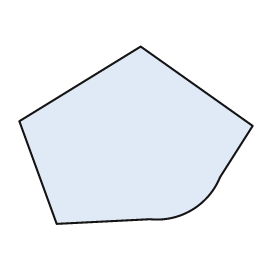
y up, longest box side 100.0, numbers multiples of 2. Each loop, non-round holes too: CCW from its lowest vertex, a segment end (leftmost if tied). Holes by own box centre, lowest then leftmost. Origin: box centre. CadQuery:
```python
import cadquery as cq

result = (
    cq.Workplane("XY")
    .moveTo(-34.0, -38.0)
    .lineTo(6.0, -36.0)
    .threePointArc((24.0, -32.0), (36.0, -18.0))
    .lineTo(50.0, 4.0)
    .lineTo(2.0, 38.0)
    .lineTo(-50.0, 6.0)
    .close()
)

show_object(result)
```